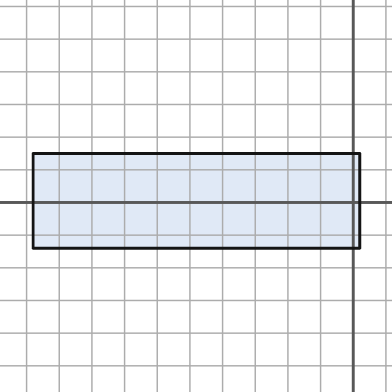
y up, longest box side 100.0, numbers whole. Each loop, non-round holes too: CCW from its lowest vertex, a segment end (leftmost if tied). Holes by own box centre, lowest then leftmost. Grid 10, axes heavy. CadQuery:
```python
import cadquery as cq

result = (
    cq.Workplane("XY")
    .moveTo(-98.0, -14.0)
    .lineTo(2.0, -14.0)
    .lineTo(2.0, 15.0)
    .lineTo(-98.0, 15.0)
    .close()
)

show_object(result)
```